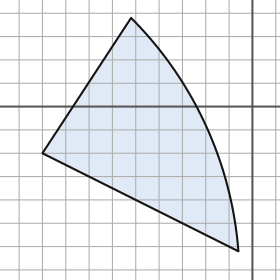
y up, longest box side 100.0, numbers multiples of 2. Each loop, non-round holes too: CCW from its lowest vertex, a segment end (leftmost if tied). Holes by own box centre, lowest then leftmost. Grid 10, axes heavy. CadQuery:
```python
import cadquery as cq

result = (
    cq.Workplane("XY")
    .moveTo(-6.0, -62.0)
    .threePointArc((-20.0, -8.0), (-52.0, 38.0))
    .lineTo(-90.0, -20.0)
    .close()
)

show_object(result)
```